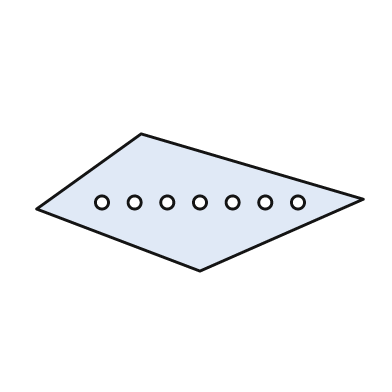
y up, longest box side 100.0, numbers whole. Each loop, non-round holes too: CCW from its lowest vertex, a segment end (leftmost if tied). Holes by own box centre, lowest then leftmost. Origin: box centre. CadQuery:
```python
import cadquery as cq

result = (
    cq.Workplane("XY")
    .moveTo(0.0, -21.0)
    .lineTo(50.0, 1.0)
    .lineTo(-18.0, 21.0)
    .lineTo(-50.0, -2.0)
    .close()
    .moveTo(-30.0, 0.0)
    .circle(2.0)
    .moveTo(-20.0, 0.0)
    .circle(2.0)
    .moveTo(-10.0, 0.0)
    .circle(2.0)
    .moveTo(0.0, 0.0)
    .circle(2.0)
    .moveTo(10.0, 0.0)
    .circle(2.0)
    .moveTo(20.0, 0.0)
    .circle(2.0)
    .moveTo(30.0, 0.0)
    .circle(2.0)
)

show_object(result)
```